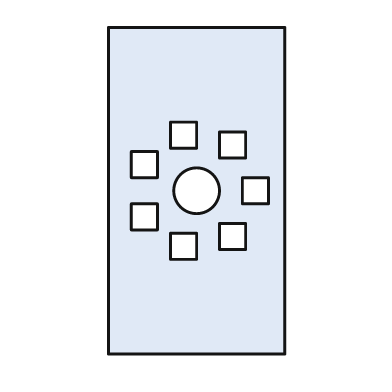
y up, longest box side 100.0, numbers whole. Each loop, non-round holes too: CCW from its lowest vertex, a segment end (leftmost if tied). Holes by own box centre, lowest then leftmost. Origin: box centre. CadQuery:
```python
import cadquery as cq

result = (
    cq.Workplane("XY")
    .moveTo(-27.0, -50.0)
    .lineTo(27.0, -50.0)
    .lineTo(27.0, 50.0)
    .lineTo(-27.0, 50.0)
    .close()
    .moveTo(-8.0, -21.0)
    .lineTo(0.0, -21.0)
    .lineTo(0.0, -13.0)
    .lineTo(-8.0, -13.0)
    .close()
    .moveTo(7.0, -18.0)
    .lineTo(15.0, -18.0)
    .lineTo(15.0, -10.0)
    .lineTo(7.0, -10.0)
    .close()
    .moveTo(-20.0, -12.0)
    .lineTo(-12.0, -12.0)
    .lineTo(-12.0, -4.0)
    .lineTo(-20.0, -4.0)
    .close()
    .moveTo(0.0, 0.0)
    .circle(7.0)
    .moveTo(14.0, -4.0)
    .lineTo(22.0, -4.0)
    .lineTo(22.0, 4.0)
    .lineTo(14.0, 4.0)
    .close()
    .moveTo(-20.0, 4.0)
    .lineTo(-12.0, 4.0)
    .lineTo(-12.0, 12.0)
    .lineTo(-20.0, 12.0)
    .close()
    .moveTo(7.0, 10.0)
    .lineTo(15.0, 10.0)
    .lineTo(15.0, 18.0)
    .lineTo(7.0, 18.0)
    .close()
    .moveTo(-8.0, 13.0)
    .lineTo(0.0, 13.0)
    .lineTo(0.0, 21.0)
    .lineTo(-8.0, 21.0)
    .close()
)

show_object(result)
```